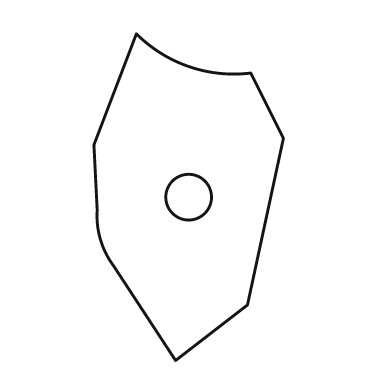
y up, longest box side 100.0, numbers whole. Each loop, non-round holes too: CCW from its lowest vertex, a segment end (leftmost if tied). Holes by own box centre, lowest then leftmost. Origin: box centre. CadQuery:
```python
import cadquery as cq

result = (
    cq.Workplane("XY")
    .moveTo(-4.0, -50.0)
    .lineTo(18.0, -33.0)
    .lineTo(29.0, 18.0)
    .lineTo(19.0, 38.0)
    .threePointArc((0.0, 40.0), (-16.0, 50.0))
    .lineTo(-29.0, 16.0)
    .lineTo(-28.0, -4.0)
    .threePointArc((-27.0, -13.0), (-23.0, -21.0))
    .close()
    .moveTo(0.0, 0.0)
    .circle(7.0)
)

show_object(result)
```